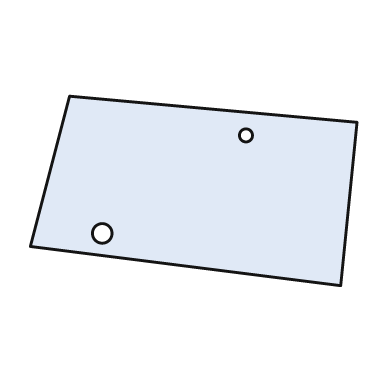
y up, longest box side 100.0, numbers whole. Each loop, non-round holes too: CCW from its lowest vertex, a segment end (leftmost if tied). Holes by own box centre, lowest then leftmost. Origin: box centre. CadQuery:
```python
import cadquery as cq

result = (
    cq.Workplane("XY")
    .moveTo(45.0, -29.0)
    .lineTo(50.0, 21.0)
    .lineTo(-38.0, 29.0)
    .lineTo(-50.0, -17.0)
    .close()
    .moveTo(-28.0, -13.0)
    .circle(3.0)
    .moveTo(16.0, 17.0)
    .circle(2.0)
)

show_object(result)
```